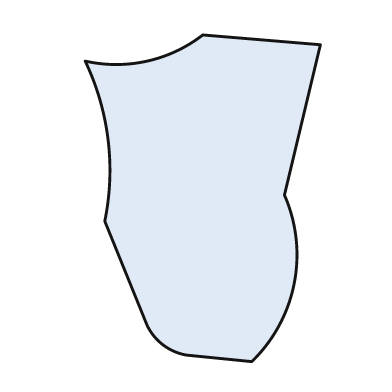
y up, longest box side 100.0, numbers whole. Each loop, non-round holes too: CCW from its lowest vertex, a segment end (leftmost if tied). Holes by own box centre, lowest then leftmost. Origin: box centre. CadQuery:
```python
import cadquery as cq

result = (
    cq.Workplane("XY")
    .moveTo(15.0, -50.0)
    .threePointArc((28.0, -26.0), (25.0, 1.0))
    .lineTo(36.0, 47.0)
    .lineTo(0.0, 50.0)
    .threePointArc((-17.0, 42.0), (-36.0, 42.0))
    .threePointArc((-29.0, 18.0), (-30.0, -7.0))
    .lineTo(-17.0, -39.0)
    .threePointArc((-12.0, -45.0), (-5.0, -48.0))
    .close()
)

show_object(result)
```